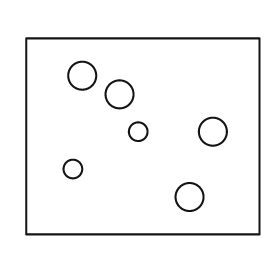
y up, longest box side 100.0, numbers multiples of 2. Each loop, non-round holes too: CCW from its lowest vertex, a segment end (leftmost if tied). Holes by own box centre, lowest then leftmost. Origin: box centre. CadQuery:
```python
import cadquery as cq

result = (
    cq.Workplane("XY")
    .moveTo(-50.0, -42.0)
    .lineTo(50.0, -42.0)
    .lineTo(50.0, 42.0)
    .lineTo(-50.0, 42.0)
    .close()
    .moveTo(20.0, -26.0)
    .circle(6.0)
    .moveTo(-30.0, -14.0)
    .circle(4.0)
    .moveTo(-2.0, 2.0)
    .circle(4.0)
    .moveTo(30.0, 2.0)
    .circle(6.0)
    .moveTo(-10.0, 18.0)
    .circle(6.0)
    .moveTo(-26.0, 26.0)
    .circle(6.0)
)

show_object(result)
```